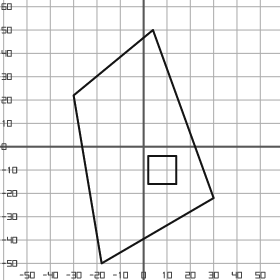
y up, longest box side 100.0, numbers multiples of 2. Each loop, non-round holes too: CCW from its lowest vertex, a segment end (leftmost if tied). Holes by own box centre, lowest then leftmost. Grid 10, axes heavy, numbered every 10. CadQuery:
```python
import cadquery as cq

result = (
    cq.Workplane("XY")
    .moveTo(-18.0, -50.0)
    .lineTo(30.0, -22.0)
    .lineTo(4.0, 50.0)
    .lineTo(-30.0, 22.0)
    .close()
    .moveTo(2.0, -16.0)
    .lineTo(14.0, -16.0)
    .lineTo(14.0, -4.0)
    .lineTo(2.0, -4.0)
    .close()
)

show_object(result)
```